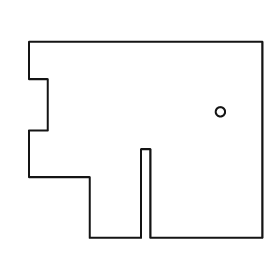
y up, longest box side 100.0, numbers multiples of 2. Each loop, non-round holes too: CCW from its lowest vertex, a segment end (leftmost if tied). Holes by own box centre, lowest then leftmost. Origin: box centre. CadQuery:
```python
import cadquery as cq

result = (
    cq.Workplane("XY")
    .moveTo(-24.0, -42.0)
    .lineTo(-2.0, -42.0)
    .lineTo(-2.0, -4.0)
    .lineTo(2.0, -4.0)
    .lineTo(2.0, -42.0)
    .lineTo(50.0, -42.0)
    .lineTo(50.0, 42.0)
    .lineTo(-50.0, 42.0)
    .lineTo(-50.0, 26.0)
    .lineTo(-42.0, 26.0)
    .lineTo(-42.0, 4.0)
    .lineTo(-50.0, 4.0)
    .lineTo(-50.0, -16.0)
    .lineTo(-24.0, -16.0)
    .close()
    .moveTo(32.0, 12.0)
    .circle(2.0)
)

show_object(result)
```